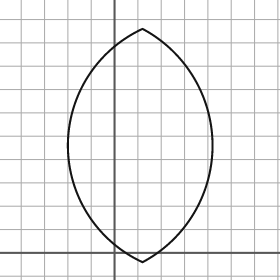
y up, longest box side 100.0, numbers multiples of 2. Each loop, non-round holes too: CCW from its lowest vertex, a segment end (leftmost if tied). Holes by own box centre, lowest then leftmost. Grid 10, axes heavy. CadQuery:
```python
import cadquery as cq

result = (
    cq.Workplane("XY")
    .moveTo(12.0, -4.0)
    .threePointArc((42.0, 46.0), (12.0, 96.0))
    .threePointArc((-20.0, 46.0), (12.0, -4.0))
    .close()
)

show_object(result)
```